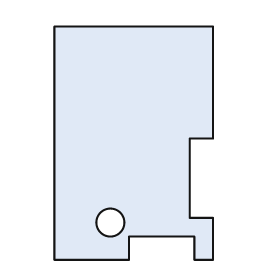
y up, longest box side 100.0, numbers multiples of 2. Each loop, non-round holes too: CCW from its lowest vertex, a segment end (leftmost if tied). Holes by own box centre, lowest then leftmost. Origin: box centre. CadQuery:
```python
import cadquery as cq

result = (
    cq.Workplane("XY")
    .moveTo(-34.0, -50.0)
    .lineTo(-2.0, -50.0)
    .lineTo(-2.0, -40.0)
    .lineTo(26.0, -40.0)
    .lineTo(26.0, -50.0)
    .lineTo(34.0, -50.0)
    .lineTo(34.0, -32.0)
    .lineTo(24.0, -32.0)
    .lineTo(24.0, 2.0)
    .lineTo(34.0, 2.0)
    .lineTo(34.0, 50.0)
    .lineTo(-34.0, 50.0)
    .close()
    .moveTo(-10.0, -34.0)
    .circle(6.0)
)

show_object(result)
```